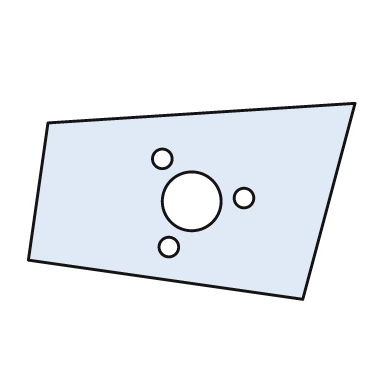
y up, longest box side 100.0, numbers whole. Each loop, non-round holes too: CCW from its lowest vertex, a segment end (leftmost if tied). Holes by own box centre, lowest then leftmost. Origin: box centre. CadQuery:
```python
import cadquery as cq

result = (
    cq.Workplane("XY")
    .moveTo(34.0, -30.0)
    .lineTo(50.0, 30.0)
    .lineTo(-44.0, 24.0)
    .lineTo(-50.0, -18.0)
    .close()
    .moveTo(-7.0, -14.0)
    .circle(3.0)
    .moveTo(0.0, 0.0)
    .circle(9.0)
    .moveTo(16.0, 1.0)
    .circle(3.0)
    .moveTo(-9.0, 13.0)
    .circle(3.0)
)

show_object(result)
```